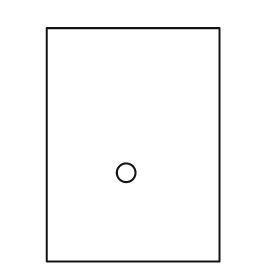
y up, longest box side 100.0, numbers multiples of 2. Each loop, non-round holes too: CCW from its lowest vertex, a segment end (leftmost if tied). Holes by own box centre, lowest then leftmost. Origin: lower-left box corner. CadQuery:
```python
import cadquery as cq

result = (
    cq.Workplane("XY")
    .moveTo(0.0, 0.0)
    .lineTo(74.0, 0.0)
    .lineTo(74.0, 100.0)
    .lineTo(0.0, 100.0)
    .close()
    .moveTo(34.0, 38.0)
    .circle(4.0)
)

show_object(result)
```